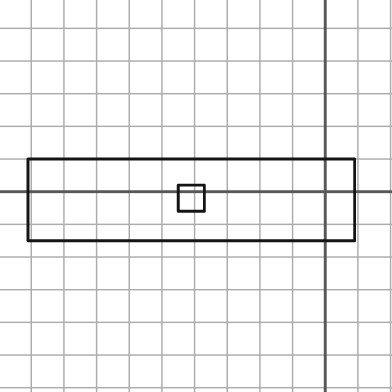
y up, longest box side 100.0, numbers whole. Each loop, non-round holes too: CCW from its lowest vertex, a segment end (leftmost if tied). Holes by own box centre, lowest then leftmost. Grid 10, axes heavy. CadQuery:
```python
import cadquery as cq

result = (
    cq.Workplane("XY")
    .moveTo(-91.0, -15.0)
    .lineTo(9.0, -15.0)
    .lineTo(9.0, 10.0)
    .lineTo(-91.0, 10.0)
    .close()
    .moveTo(-45.0, -6.0)
    .lineTo(-37.0, -6.0)
    .lineTo(-37.0, 2.0)
    .lineTo(-45.0, 2.0)
    .close()
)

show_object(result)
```